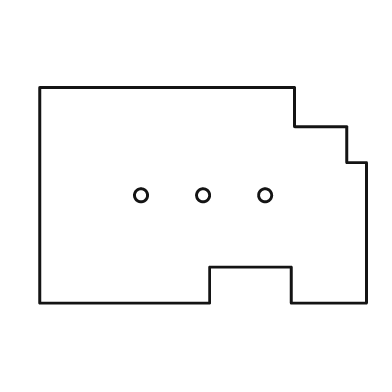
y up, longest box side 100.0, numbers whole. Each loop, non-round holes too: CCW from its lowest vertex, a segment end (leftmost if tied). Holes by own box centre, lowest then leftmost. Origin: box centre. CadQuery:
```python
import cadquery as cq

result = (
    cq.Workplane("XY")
    .moveTo(-50.0, -33.0)
    .lineTo(2.0, -33.0)
    .lineTo(2.0, -22.0)
    .lineTo(27.0, -22.0)
    .lineTo(27.0, -33.0)
    .lineTo(50.0, -33.0)
    .lineTo(50.0, 10.0)
    .lineTo(44.0, 10.0)
    .lineTo(44.0, 21.0)
    .lineTo(28.0, 21.0)
    .lineTo(28.0, 33.0)
    .lineTo(-50.0, 33.0)
    .close()
    .moveTo(-19.0, 0.0)
    .circle(2.0)
    .moveTo(0.0, 0.0)
    .circle(2.0)
    .moveTo(19.0, 0.0)
    .circle(2.0)
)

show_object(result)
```